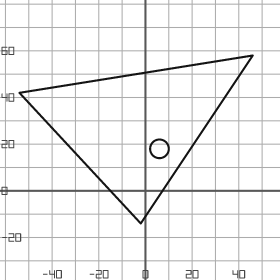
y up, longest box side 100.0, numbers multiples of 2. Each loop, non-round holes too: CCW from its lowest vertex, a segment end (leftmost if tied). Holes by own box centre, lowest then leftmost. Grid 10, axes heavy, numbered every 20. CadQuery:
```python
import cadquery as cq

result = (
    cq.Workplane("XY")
    .moveTo(-2.0, -14.0)
    .lineTo(46.0, 58.0)
    .lineTo(-54.0, 42.0)
    .close()
    .moveTo(6.0, 18.0)
    .circle(4.0)
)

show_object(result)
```